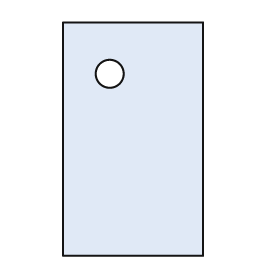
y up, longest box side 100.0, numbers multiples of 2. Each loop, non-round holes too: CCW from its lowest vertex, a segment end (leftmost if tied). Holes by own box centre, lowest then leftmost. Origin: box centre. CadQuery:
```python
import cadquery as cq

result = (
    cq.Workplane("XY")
    .moveTo(-30.0, -50.0)
    .lineTo(30.0, -50.0)
    .lineTo(30.0, 50.0)
    .lineTo(-30.0, 50.0)
    .close()
    .moveTo(-10.0, 28.0)
    .circle(6.0)
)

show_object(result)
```